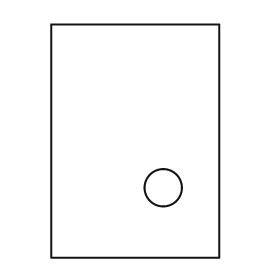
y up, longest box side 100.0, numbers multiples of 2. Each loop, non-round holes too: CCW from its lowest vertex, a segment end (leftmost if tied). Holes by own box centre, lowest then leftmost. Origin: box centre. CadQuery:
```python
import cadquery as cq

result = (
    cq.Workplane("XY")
    .moveTo(-36.0, -50.0)
    .lineTo(36.0, -50.0)
    .lineTo(36.0, 50.0)
    .lineTo(-36.0, 50.0)
    .close()
    .moveTo(12.0, -20.0)
    .circle(8.0)
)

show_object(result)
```